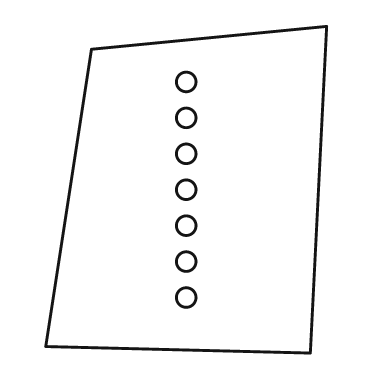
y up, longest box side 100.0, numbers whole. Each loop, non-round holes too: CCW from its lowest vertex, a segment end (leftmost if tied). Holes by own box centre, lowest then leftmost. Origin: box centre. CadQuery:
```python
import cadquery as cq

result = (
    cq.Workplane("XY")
    .moveTo(38.0, -50.0)
    .lineTo(43.0, 50.0)
    .lineTo(-29.0, 43.0)
    .lineTo(-43.0, -48.0)
    .close()
    .moveTo(0.0, -33.0)
    .circle(3.0)
    .moveTo(0.0, -22.0)
    .circle(3.0)
    .moveTo(0.0, -11.0)
    .circle(3.0)
    .moveTo(0.0, 0.0)
    .circle(3.0)
    .moveTo(0.0, 11.0)
    .circle(3.0)
    .moveTo(0.0, 22.0)
    .circle(3.0)
    .moveTo(0.0, 33.0)
    .circle(3.0)
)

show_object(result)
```